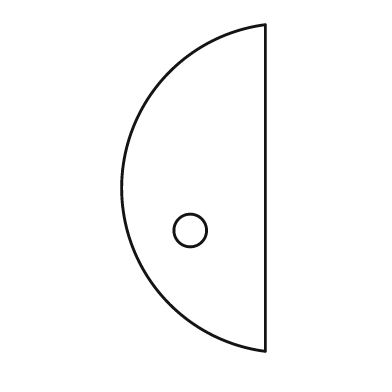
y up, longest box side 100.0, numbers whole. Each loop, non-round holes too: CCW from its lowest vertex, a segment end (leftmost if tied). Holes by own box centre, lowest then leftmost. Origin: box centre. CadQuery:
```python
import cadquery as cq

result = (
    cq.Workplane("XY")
    .moveTo(22.0, -50.0)
    .lineTo(22.0, 50.0)
    .threePointArc((-22.0, 0.0), (22.0, -50.0))
    .close()
    .moveTo(-1.0, -13.0)
    .circle(5.0)
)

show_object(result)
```